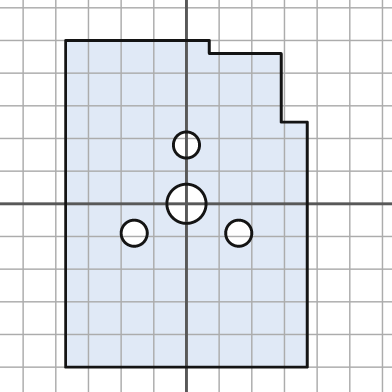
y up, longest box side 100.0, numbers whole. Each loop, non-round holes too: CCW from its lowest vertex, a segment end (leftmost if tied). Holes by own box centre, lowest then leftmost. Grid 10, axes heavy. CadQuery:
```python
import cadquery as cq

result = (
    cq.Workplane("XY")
    .moveTo(-37.0, -50.0)
    .lineTo(37.0, -50.0)
    .lineTo(37.0, 25.0)
    .lineTo(29.0, 25.0)
    .lineTo(29.0, 46.0)
    .lineTo(7.0, 46.0)
    .lineTo(7.0, 50.0)
    .lineTo(-37.0, 50.0)
    .close()
    .moveTo(-16.0, -9.0)
    .circle(4.0)
    .moveTo(16.0, -9.0)
    .circle(4.0)
    .moveTo(0.0, 0.0)
    .circle(6.0)
    .moveTo(0.0, 18.0)
    .circle(4.0)
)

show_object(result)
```